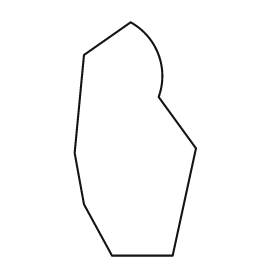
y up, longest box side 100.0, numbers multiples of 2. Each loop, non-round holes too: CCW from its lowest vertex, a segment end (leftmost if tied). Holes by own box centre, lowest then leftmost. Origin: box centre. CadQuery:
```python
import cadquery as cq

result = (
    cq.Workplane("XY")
    .moveTo(-10.0, -50.0)
    .lineTo(16.0, -50.0)
    .lineTo(26.0, -4.0)
    .lineTo(10.0, 18.0)
    .threePointArc((10.0, 36.0), (-2.0, 50.0))
    .lineTo(-22.0, 36.0)
    .lineTo(-26.0, -6.0)
    .lineTo(-22.0, -28.0)
    .close()
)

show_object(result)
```